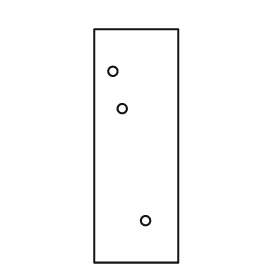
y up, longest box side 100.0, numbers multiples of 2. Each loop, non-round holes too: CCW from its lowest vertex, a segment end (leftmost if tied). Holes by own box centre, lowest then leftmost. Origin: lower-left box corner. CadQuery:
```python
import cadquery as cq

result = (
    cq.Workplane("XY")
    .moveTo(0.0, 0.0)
    .lineTo(36.0, 0.0)
    .lineTo(36.0, 100.0)
    .lineTo(0.0, 100.0)
    .close()
    .moveTo(22.0, 18.0)
    .circle(2.0)
    .moveTo(12.0, 66.0)
    .circle(2.0)
    .moveTo(8.0, 82.0)
    .circle(2.0)
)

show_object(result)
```